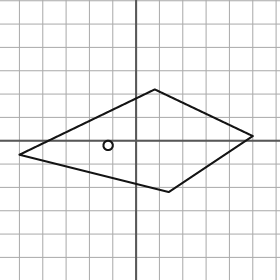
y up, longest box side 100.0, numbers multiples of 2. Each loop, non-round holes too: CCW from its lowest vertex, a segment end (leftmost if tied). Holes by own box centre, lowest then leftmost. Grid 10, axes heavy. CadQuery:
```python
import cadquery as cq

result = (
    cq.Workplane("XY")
    .moveTo(14.0, -22.0)
    .lineTo(50.0, 2.0)
    .lineTo(8.0, 22.0)
    .lineTo(-50.0, -6.0)
    .close()
    .moveTo(-12.0, -2.0)
    .circle(2.0)
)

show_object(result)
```